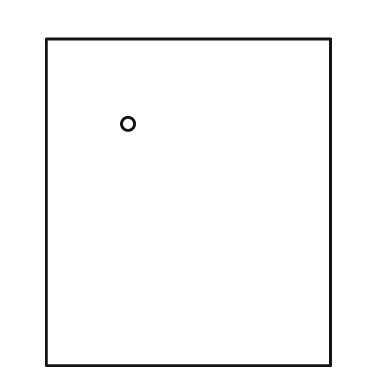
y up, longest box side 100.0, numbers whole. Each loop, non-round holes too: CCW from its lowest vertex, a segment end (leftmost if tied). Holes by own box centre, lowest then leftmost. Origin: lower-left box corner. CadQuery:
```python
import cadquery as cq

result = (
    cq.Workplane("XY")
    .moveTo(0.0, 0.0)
    .lineTo(87.0, 0.0)
    .lineTo(87.0, 100.0)
    .lineTo(0.0, 100.0)
    .close()
    .moveTo(25.0, 74.0)
    .circle(2.0)
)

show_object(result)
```